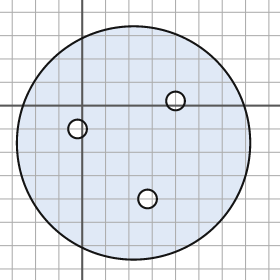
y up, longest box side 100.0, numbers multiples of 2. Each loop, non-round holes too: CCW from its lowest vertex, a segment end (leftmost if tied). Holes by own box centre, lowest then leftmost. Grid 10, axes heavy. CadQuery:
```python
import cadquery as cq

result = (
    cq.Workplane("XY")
    .moveTo(22.0, -16.0)
    .circle(50.0)
    .moveTo(28.0, -40.0)
    .circle(4.0)
    .moveTo(-2.0, -10.0)
    .circle(4.0)
    .moveTo(40.0, 2.0)
    .circle(4.0)
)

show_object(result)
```